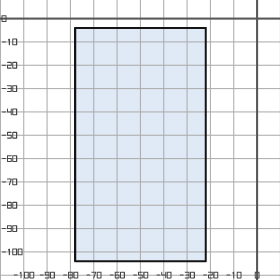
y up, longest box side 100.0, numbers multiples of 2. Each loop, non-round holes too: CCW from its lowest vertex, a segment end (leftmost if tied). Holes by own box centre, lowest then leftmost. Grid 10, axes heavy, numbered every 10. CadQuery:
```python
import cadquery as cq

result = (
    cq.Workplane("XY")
    .moveTo(-78.0, -104.0)
    .lineTo(-22.0, -104.0)
    .lineTo(-22.0, -4.0)
    .lineTo(-78.0, -4.0)
    .close()
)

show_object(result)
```